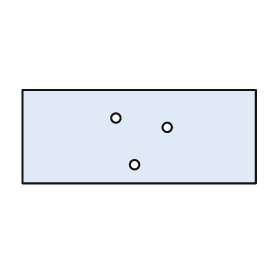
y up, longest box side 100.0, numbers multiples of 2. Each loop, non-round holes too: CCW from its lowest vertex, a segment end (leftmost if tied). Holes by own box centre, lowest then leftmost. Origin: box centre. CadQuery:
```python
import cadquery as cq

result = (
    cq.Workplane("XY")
    .moveTo(-50.0, -20.0)
    .lineTo(50.0, -20.0)
    .lineTo(50.0, 20.0)
    .lineTo(-50.0, 20.0)
    .close()
    .moveTo(-2.0, -12.0)
    .circle(2.0)
    .moveTo(12.0, 4.0)
    .circle(2.0)
    .moveTo(-10.0, 8.0)
    .circle(2.0)
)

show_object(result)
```